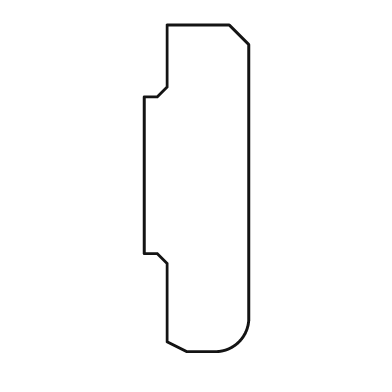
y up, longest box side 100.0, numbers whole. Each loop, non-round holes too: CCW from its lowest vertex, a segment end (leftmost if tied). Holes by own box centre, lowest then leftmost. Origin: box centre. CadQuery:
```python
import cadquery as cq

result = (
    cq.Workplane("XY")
    .moveTo(-3.0, -50.0)
    .lineTo(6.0, -50.0)
    .threePointArc((13.0, -47.0), (16.0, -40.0))
    .lineTo(16.0, 44.0)
    .lineTo(10.0, 50.0)
    .lineTo(-9.0, 50.0)
    .lineTo(-9.0, 31.0)
    .lineTo(-12.0, 28.0)
    .lineTo(-16.0, 28.0)
    .lineTo(-16.0, -20.0)
    .lineTo(-12.0, -20.0)
    .lineTo(-9.0, -23.0)
    .lineTo(-9.0, -47.0)
    .close()
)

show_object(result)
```